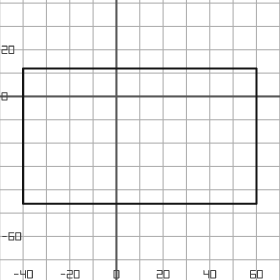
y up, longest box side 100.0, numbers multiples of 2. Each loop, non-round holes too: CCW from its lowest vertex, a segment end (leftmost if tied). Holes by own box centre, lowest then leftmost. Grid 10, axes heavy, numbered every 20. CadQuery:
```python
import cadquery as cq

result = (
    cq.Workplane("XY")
    .moveTo(-40.0, -46.0)
    .lineTo(60.0, -46.0)
    .lineTo(60.0, 12.0)
    .lineTo(-40.0, 12.0)
    .close()
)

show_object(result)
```